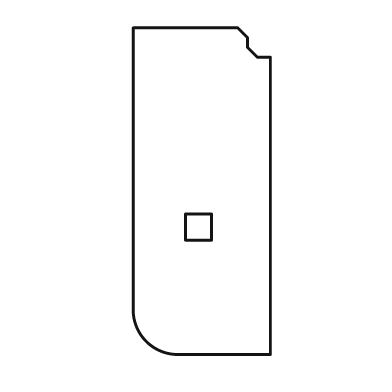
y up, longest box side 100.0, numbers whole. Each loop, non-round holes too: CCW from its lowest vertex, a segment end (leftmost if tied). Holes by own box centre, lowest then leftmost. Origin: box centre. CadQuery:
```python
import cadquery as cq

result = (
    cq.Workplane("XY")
    .moveTo(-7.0, -50.0)
    .lineTo(21.0, -50.0)
    .lineTo(21.0, 41.0)
    .lineTo(17.0, 41.0)
    .lineTo(14.0, 44.0)
    .lineTo(14.0, 47.0)
    .lineTo(11.0, 50.0)
    .lineTo(-21.0, 50.0)
    .lineTo(-21.0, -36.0)
    .threePointArc((-17.0, -46.0), (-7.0, -50.0))
    .close()
    .moveTo(-5.0, -15.0)
    .lineTo(3.0, -15.0)
    .lineTo(3.0, -7.0)
    .lineTo(-5.0, -7.0)
    .close()
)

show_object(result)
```